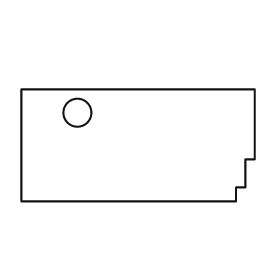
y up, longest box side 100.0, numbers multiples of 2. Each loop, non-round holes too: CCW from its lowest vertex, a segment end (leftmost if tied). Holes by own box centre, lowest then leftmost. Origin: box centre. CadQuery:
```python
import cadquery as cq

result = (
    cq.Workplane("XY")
    .moveTo(-50.0, -24.0)
    .lineTo(42.0, -24.0)
    .lineTo(42.0, -18.0)
    .lineTo(46.0, -18.0)
    .lineTo(46.0, -6.0)
    .lineTo(50.0, -6.0)
    .lineTo(50.0, 24.0)
    .lineTo(-50.0, 24.0)
    .close()
    .moveTo(-26.0, 14.0)
    .circle(6.0)
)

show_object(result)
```